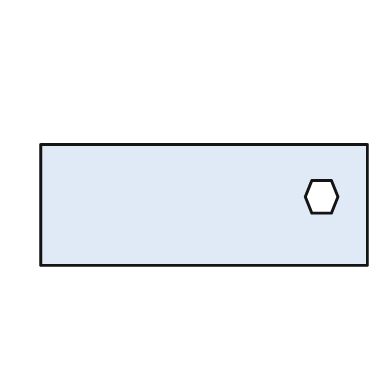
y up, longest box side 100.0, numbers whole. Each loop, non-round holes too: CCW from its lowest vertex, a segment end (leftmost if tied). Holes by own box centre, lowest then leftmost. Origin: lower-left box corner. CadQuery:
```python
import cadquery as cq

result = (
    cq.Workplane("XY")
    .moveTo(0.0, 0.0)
    .lineTo(100.0, 0.0)
    .lineTo(100.0, 37.0)
    .lineTo(0.0, 37.0)
    .close()
    .moveTo(83.0, 16.0)
    .lineTo(89.0, 16.0)
    .lineTo(91.0, 21.0)
    .lineTo(89.0, 26.0)
    .lineTo(83.0, 26.0)
    .lineTo(81.0, 21.0)
    .close()
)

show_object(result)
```